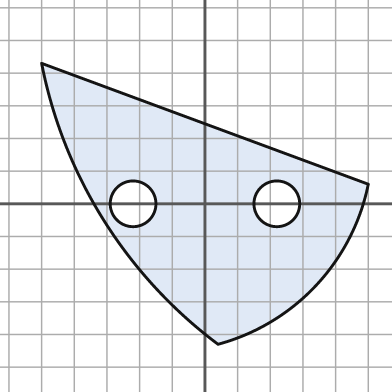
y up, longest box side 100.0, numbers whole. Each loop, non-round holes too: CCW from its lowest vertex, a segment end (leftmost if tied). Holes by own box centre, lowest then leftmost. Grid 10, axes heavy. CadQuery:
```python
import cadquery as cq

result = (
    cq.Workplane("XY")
    .moveTo(4.0, -43.0)
    .threePointArc((34.0, -25.0), (50.0, 6.0))
    .lineTo(-50.0, 43.0)
    .threePointArc((-31.0, -5.0), (4.0, -43.0))
    .close()
    .moveTo(-22.0, 0.0)
    .circle(7.0)
    .moveTo(22.0, 0.0)
    .circle(7.0)
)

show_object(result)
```